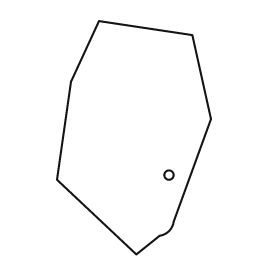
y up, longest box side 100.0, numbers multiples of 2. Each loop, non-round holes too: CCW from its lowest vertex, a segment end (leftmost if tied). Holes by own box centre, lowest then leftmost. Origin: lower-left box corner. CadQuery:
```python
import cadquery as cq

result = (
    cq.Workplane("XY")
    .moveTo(34.0, 0.0)
    .lineTo(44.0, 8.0)
    .threePointArc((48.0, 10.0), (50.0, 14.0))
    .lineTo(66.0, 58.0)
    .lineTo(58.0, 94.0)
    .lineTo(18.0, 100.0)
    .lineTo(6.0, 74.0)
    .lineTo(0.0, 32.0)
    .close()
    .moveTo(48.0, 34.0)
    .circle(2.0)
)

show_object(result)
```